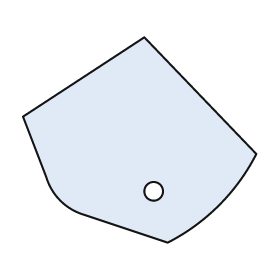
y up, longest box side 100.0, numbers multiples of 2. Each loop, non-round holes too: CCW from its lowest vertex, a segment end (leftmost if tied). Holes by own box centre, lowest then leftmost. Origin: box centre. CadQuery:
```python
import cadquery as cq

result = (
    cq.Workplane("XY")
    .moveTo(12.0, -44.0)
    .threePointArc((34.0, -28.0), (50.0, -6.0))
    .lineTo(2.0, 44.0)
    .lineTo(-50.0, 10.0)
    .lineTo(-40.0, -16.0)
    .threePointArc((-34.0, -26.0), (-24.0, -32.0))
    .close()
    .moveTo(6.0, -22.0)
    .circle(4.0)
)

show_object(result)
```